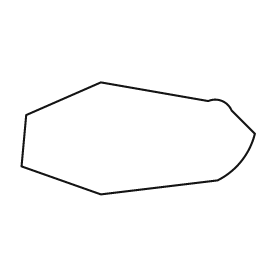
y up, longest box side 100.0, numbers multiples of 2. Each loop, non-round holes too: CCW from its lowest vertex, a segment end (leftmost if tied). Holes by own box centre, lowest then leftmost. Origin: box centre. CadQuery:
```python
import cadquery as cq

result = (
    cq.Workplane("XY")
    .moveTo(-16.0, -24.0)
    .lineTo(34.0, -18.0)
    .threePointArc((44.0, -10.0), (50.0, 2.0))
    .lineTo(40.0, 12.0)
    .threePointArc((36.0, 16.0), (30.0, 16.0))
    .lineTo(-16.0, 24.0)
    .lineTo(-48.0, 10.0)
    .lineTo(-50.0, -12.0)
    .close()
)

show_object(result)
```